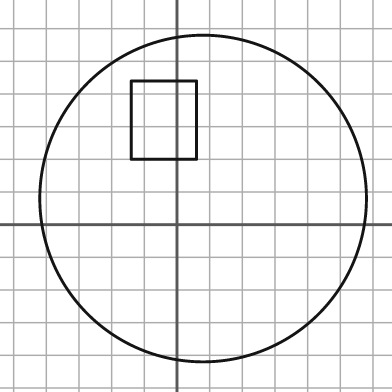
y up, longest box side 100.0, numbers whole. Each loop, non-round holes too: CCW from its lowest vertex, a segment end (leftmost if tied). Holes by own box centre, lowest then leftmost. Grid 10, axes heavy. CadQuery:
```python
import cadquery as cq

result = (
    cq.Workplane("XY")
    .moveTo(8.0, 8.0)
    .circle(50.0)
    .moveTo(-14.0, 20.0)
    .lineTo(6.0, 20.0)
    .lineTo(6.0, 44.0)
    .lineTo(-14.0, 44.0)
    .close()
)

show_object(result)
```